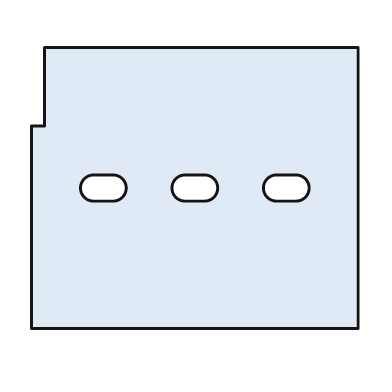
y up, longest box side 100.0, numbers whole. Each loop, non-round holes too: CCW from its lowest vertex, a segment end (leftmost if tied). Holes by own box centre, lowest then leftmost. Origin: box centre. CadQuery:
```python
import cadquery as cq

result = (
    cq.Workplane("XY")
    .moveTo(-50.0, -43.0)
    .lineTo(50.0, -43.0)
    .lineTo(50.0, 43.0)
    .lineTo(-46.0, 43.0)
    .lineTo(-46.0, 19.0)
    .lineTo(-50.0, 19.0)
    .close()
    .moveTo(-31.0, -4.0)
    .lineTo(-25.0, -4.0)
    .threePointArc((-21.0, 0.0), (-25.0, 4.0))
    .lineTo(-31.0, 4.0)
    .threePointArc((-35.0, 0.0), (-31.0, -4.0))
    .close()
    .moveTo(-3.0, -4.0)
    .lineTo(3.0, -4.0)
    .threePointArc((7.0, 0.0), (3.0, 4.0))
    .lineTo(-3.0, 4.0)
    .threePointArc((-7.0, 0.0), (-3.0, -4.0))
    .close()
    .moveTo(25.0, -4.0)
    .lineTo(31.0, -4.0)
    .threePointArc((35.0, 0.0), (31.0, 4.0))
    .lineTo(25.0, 4.0)
    .threePointArc((21.0, 0.0), (25.0, -4.0))
    .close()
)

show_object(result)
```